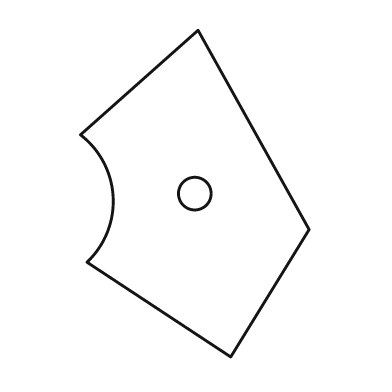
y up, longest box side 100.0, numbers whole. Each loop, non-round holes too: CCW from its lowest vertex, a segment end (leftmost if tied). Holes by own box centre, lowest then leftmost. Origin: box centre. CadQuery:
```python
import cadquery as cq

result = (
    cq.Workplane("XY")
    .moveTo(11.0, -50.0)
    .lineTo(35.0, -11.0)
    .lineTo(1.0, 50.0)
    .lineTo(-35.0, 18.0)
    .threePointArc((-25.0, -1.0), (-33.0, -21.0))
    .close()
    .moveTo(0.0, 0.0)
    .circle(5.0)
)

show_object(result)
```